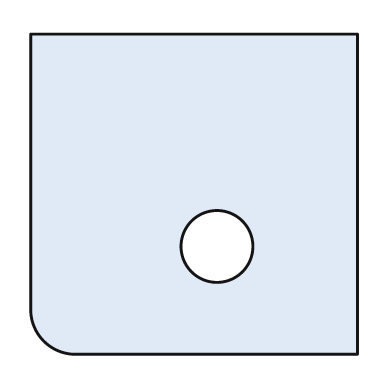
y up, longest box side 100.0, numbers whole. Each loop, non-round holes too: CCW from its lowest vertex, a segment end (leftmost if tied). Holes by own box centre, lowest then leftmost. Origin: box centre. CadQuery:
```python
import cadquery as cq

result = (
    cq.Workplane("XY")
    .moveTo(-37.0, -49.0)
    .lineTo(50.0, -49.0)
    .lineTo(50.0, 49.0)
    .lineTo(-50.0, 49.0)
    .lineTo(-50.0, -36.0)
    .threePointArc((-46.0, -45.0), (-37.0, -49.0))
    .close()
    .moveTo(7.0, -16.0)
    .circle(11.0)
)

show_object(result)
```